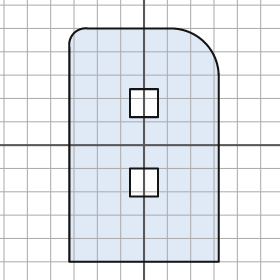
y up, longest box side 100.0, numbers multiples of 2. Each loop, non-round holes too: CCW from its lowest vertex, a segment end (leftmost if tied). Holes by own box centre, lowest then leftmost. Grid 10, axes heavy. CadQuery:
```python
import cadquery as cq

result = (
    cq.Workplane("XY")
    .moveTo(-32.0, -50.0)
    .lineTo(32.0, -50.0)
    .lineTo(32.0, 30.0)
    .threePointArc((26.0, 44.0), (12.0, 50.0))
    .lineTo(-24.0, 50.0)
    .threePointArc((-30.0, 48.0), (-32.0, 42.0))
    .close()
    .moveTo(-6.0, -22.0)
    .lineTo(6.0, -22.0)
    .lineTo(6.0, -10.0)
    .lineTo(-6.0, -10.0)
    .close()
    .moveTo(-6.0, 12.0)
    .lineTo(6.0, 12.0)
    .lineTo(6.0, 24.0)
    .lineTo(-6.0, 24.0)
    .close()
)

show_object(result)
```